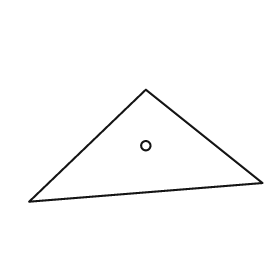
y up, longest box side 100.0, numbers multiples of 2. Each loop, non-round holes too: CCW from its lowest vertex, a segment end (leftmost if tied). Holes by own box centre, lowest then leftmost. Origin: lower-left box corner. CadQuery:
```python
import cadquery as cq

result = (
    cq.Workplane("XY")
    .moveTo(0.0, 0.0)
    .lineTo(100.0, 8.0)
    .lineTo(50.0, 48.0)
    .close()
    .moveTo(50.0, 24.0)
    .circle(2.0)
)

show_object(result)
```